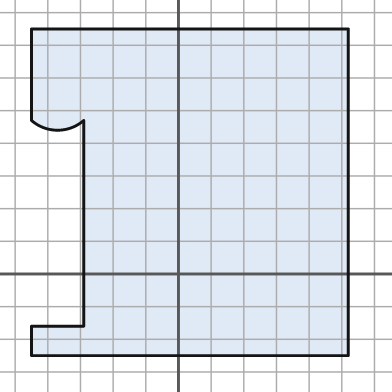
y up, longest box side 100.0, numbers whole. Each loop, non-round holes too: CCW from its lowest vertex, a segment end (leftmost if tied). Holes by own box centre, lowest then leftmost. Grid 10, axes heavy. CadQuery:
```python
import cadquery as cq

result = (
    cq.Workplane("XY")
    .moveTo(-45.0, -25.0)
    .lineTo(52.0, -25.0)
    .lineTo(52.0, 75.0)
    .lineTo(-45.0, 75.0)
    .lineTo(-45.0, 47.0)
    .threePointArc((-37.0, 44.0), (-29.0, 47.0))
    .lineTo(-29.0, -16.0)
    .lineTo(-45.0, -16.0)
    .close()
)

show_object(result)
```